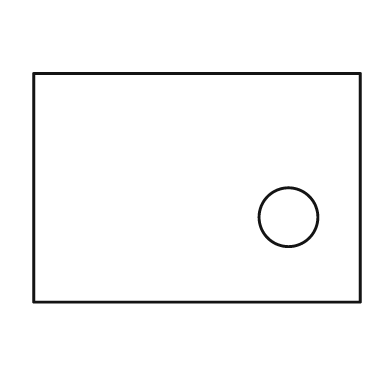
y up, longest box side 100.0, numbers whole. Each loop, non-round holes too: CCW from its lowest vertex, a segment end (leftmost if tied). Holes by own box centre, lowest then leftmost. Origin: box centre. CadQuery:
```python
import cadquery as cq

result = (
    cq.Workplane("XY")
    .moveTo(-50.0, -35.0)
    .lineTo(50.0, -35.0)
    .lineTo(50.0, 35.0)
    .lineTo(-50.0, 35.0)
    .close()
    .moveTo(28.0, -9.0)
    .circle(9.0)
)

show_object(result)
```